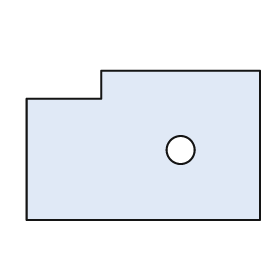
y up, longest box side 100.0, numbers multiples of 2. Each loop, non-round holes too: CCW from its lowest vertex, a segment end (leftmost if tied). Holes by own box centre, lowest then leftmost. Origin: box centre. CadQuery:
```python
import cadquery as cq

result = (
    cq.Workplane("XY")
    .moveTo(-50.0, -32.0)
    .lineTo(50.0, -32.0)
    .lineTo(50.0, 32.0)
    .lineTo(-18.0, 32.0)
    .lineTo(-18.0, 20.0)
    .lineTo(-50.0, 20.0)
    .close()
    .moveTo(16.0, -2.0)
    .circle(6.0)
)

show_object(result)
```